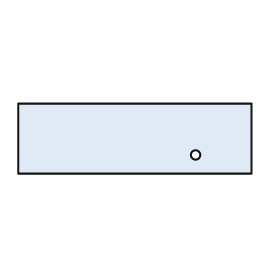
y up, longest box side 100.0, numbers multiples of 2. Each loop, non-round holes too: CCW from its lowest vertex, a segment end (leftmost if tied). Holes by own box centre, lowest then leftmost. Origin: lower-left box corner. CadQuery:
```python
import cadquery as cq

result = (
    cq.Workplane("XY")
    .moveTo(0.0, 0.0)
    .lineTo(100.0, 0.0)
    .lineTo(100.0, 30.0)
    .lineTo(0.0, 30.0)
    .close()
    .moveTo(76.0, 8.0)
    .circle(2.0)
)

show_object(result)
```